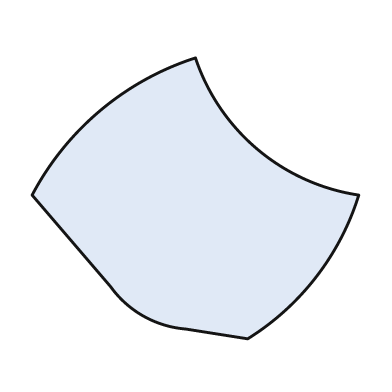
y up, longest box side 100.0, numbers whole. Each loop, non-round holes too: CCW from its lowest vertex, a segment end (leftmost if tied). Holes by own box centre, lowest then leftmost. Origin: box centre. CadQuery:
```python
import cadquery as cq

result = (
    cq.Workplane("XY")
    .moveTo(16.0, -43.0)
    .threePointArc((37.0, -24.0), (50.0, 1.0))
    .threePointArc((19.0, 15.0), (0.0, 43.0))
    .threePointArc((-29.0, 27.0), (-50.0, 1.0))
    .lineTo(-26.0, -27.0)
    .threePointArc((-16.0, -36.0), (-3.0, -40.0))
    .close()
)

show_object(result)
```